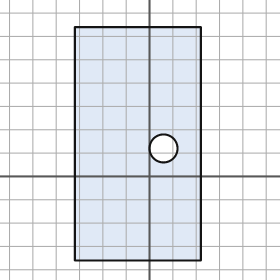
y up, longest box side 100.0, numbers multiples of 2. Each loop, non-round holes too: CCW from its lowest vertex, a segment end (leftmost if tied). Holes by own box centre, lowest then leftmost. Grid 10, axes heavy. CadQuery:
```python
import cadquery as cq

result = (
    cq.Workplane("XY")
    .moveTo(-32.0, -36.0)
    .lineTo(22.0, -36.0)
    .lineTo(22.0, 64.0)
    .lineTo(-32.0, 64.0)
    .close()
    .moveTo(6.0, 12.0)
    .circle(6.0)
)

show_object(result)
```